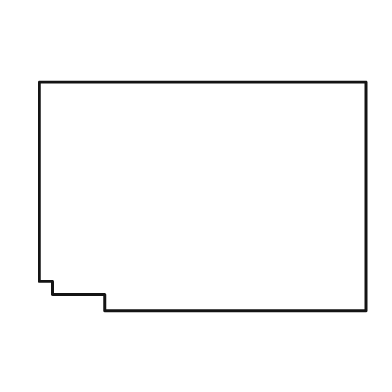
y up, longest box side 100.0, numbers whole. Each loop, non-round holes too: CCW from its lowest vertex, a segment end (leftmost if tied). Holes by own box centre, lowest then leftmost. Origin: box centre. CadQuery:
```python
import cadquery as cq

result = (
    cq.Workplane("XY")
    .moveTo(-30.0, -35.0)
    .lineTo(50.0, -35.0)
    .lineTo(50.0, 35.0)
    .lineTo(-50.0, 35.0)
    .lineTo(-50.0, -26.0)
    .lineTo(-46.0, -26.0)
    .lineTo(-46.0, -30.0)
    .lineTo(-30.0, -30.0)
    .close()
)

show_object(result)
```